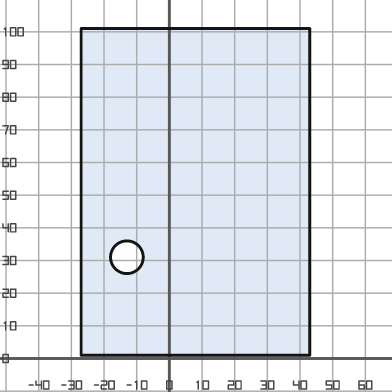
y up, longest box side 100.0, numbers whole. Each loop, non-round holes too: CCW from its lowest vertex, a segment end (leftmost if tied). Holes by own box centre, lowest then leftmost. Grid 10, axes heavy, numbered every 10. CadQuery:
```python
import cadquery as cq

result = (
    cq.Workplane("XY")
    .moveTo(-27.0, 1.0)
    .lineTo(43.0, 1.0)
    .lineTo(43.0, 101.0)
    .lineTo(-27.0, 101.0)
    .close()
    .moveTo(-13.0, 31.0)
    .circle(5.0)
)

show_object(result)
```